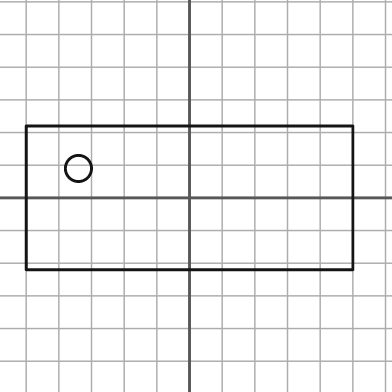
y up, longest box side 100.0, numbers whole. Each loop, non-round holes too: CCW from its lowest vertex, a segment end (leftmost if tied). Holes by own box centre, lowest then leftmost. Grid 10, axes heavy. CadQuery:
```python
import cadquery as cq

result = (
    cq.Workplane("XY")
    .moveTo(-50.0, -22.0)
    .lineTo(50.0, -22.0)
    .lineTo(50.0, 22.0)
    .lineTo(-50.0, 22.0)
    .close()
    .moveTo(-34.0, 9.0)
    .circle(4.0)
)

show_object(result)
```